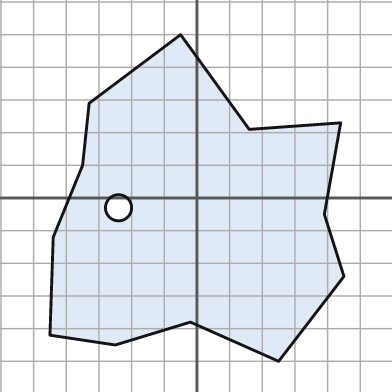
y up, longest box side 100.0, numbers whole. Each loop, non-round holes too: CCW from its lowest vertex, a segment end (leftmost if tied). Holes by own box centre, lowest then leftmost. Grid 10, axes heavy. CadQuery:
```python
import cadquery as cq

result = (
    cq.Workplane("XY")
    .moveTo(25.0, -50.0)
    .lineTo(45.0, -24.0)
    .lineTo(39.0, -5.0)
    .lineTo(44.0, 23.0)
    .lineTo(16.0, 21.0)
    .lineTo(-5.0, 50.0)
    .lineTo(-33.0, 29.0)
    .lineTo(-35.0, 10.0)
    .lineTo(-44.0, -12.0)
    .lineTo(-45.0, -42.0)
    .lineTo(-25.0, -45.0)
    .lineTo(-2.0, -38.0)
    .close()
    .moveTo(-24.0, -3.0)
    .circle(4.0)
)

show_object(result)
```